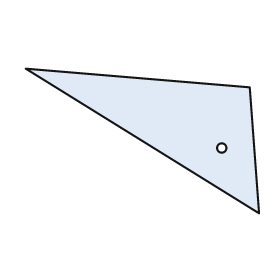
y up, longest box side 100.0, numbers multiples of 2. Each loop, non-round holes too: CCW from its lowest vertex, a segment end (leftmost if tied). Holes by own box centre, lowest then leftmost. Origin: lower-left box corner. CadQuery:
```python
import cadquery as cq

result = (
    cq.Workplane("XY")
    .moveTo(100.0, 0.0)
    .lineTo(96.0, 54.0)
    .lineTo(0.0, 62.0)
    .close()
    .moveTo(84.0, 28.0)
    .circle(2.0)
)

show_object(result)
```